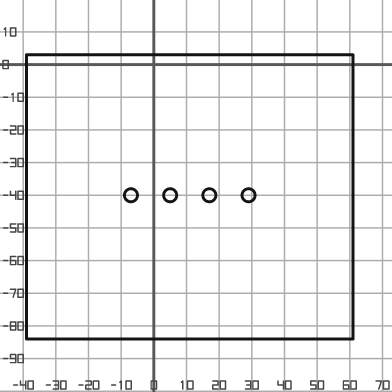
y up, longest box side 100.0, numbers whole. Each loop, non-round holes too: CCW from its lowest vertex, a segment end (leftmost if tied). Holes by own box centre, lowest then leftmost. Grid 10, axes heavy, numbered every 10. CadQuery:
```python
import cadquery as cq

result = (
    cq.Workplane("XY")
    .moveTo(-39.0, -84.0)
    .lineTo(61.0, -84.0)
    .lineTo(61.0, 3.0)
    .lineTo(-39.0, 3.0)
    .close()
    .moveTo(-7.0, -40.0)
    .circle(2.0)
    .moveTo(5.0, -40.0)
    .circle(2.0)
    .moveTo(17.0, -40.0)
    .circle(2.0)
    .moveTo(29.0, -40.0)
    .circle(2.0)
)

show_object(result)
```